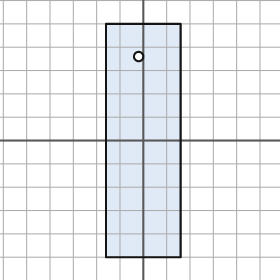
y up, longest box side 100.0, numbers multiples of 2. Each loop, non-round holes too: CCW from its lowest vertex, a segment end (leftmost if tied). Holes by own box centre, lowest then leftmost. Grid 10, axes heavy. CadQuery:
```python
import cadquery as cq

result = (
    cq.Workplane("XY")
    .moveTo(-16.0, -50.0)
    .lineTo(16.0, -50.0)
    .lineTo(16.0, 50.0)
    .lineTo(-16.0, 50.0)
    .close()
    .moveTo(-2.0, 36.0)
    .circle(2.0)
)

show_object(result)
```